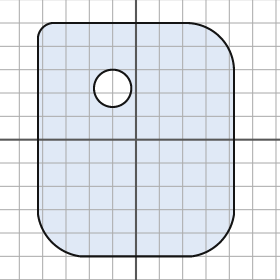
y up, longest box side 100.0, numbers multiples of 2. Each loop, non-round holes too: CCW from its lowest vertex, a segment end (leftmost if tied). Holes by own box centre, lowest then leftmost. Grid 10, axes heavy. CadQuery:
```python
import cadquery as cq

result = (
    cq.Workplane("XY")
    .moveTo(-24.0, -50.0)
    .lineTo(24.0, -50.0)
    .threePointArc((36.0, -44.0), (42.0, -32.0))
    .lineTo(42.0, 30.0)
    .threePointArc((36.0, 44.0), (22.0, 50.0))
    .lineTo(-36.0, 50.0)
    .threePointArc((-40.0, 48.0), (-42.0, 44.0))
    .lineTo(-42.0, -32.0)
    .threePointArc((-36.0, -44.0), (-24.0, -50.0))
    .close()
    .moveTo(-10.0, 22.0)
    .circle(8.0)
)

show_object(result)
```